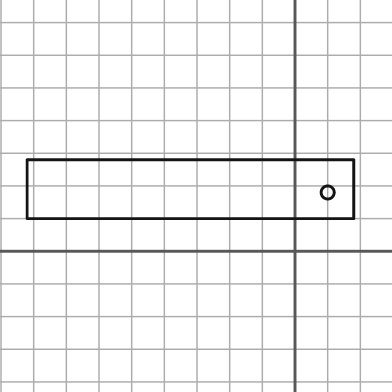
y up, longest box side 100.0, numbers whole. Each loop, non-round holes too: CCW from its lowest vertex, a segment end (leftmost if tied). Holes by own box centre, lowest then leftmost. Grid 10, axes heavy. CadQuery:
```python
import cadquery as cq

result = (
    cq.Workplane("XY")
    .moveTo(-82.0, 10.0)
    .lineTo(18.0, 10.0)
    .lineTo(18.0, 28.0)
    .lineTo(-82.0, 28.0)
    .close()
    .moveTo(10.0, 18.0)
    .circle(2.0)
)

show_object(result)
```